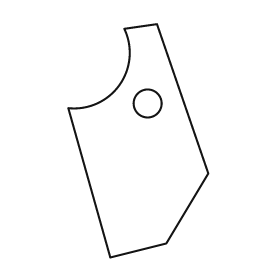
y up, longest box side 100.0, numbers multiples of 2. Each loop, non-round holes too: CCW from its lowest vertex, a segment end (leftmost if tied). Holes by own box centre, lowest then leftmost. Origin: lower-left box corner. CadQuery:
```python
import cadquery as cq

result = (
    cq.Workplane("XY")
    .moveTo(18.0, 0.0)
    .lineTo(42.0, 6.0)
    .lineTo(60.0, 36.0)
    .lineTo(38.0, 100.0)
    .lineTo(24.0, 98.0)
    .threePointArc((22.0, 74.0), (0.0, 64.0))
    .close()
    .moveTo(34.0, 66.0)
    .circle(6.0)
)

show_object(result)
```